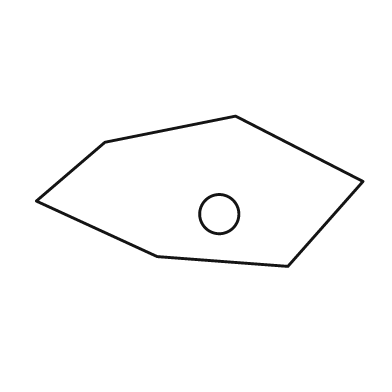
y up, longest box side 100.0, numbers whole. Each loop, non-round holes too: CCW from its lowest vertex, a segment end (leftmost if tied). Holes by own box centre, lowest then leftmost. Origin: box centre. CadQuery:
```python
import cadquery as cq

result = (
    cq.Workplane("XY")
    .moveTo(27.0, -23.0)
    .lineTo(50.0, 3.0)
    .lineTo(11.0, 23.0)
    .lineTo(-29.0, 15.0)
    .lineTo(-50.0, -3.0)
    .lineTo(-13.0, -20.0)
    .close()
    .moveTo(6.0, -7.0)
    .circle(6.0)
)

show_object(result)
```